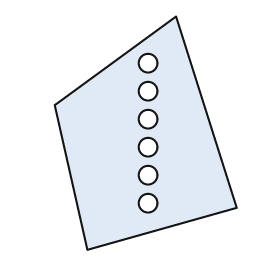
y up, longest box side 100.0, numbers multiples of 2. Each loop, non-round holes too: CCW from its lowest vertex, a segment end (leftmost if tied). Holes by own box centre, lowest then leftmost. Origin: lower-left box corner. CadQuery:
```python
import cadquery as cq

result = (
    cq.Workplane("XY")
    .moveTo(14.0, 0.0)
    .lineTo(78.0, 18.0)
    .lineTo(52.0, 100.0)
    .lineTo(0.0, 62.0)
    .close()
    .moveTo(40.0, 20.0)
    .circle(4.0)
    .moveTo(40.0, 32.0)
    .circle(4.0)
    .moveTo(40.0, 44.0)
    .circle(4.0)
    .moveTo(40.0, 56.0)
    .circle(4.0)
    .moveTo(40.0, 68.0)
    .circle(4.0)
    .moveTo(40.0, 80.0)
    .circle(4.0)
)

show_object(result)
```